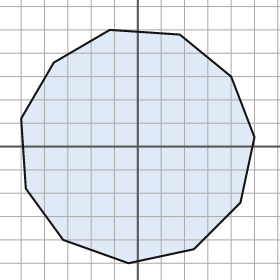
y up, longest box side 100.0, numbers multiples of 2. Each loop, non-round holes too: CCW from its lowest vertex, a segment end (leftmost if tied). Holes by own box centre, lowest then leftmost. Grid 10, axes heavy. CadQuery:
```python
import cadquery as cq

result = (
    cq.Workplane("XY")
    .moveTo(-4.0, -50.0)
    .lineTo(24.0, -44.0)
    .lineTo(44.0, -24.0)
    .lineTo(50.0, 4.0)
    .lineTo(40.0, 30.0)
    .lineTo(18.0, 48.0)
    .lineTo(-12.0, 50.0)
    .lineTo(-36.0, 36.0)
    .lineTo(-50.0, 12.0)
    .lineTo(-48.0, -18.0)
    .lineTo(-32.0, -40.0)
    .close()
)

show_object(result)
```